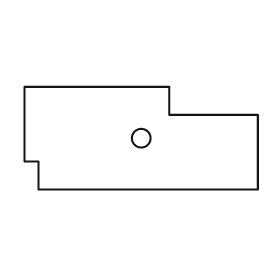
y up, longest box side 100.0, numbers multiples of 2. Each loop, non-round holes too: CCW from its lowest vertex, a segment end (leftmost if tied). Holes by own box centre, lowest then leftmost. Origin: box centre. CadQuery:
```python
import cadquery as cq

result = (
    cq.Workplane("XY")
    .moveTo(-44.0, -22.0)
    .lineTo(50.0, -22.0)
    .lineTo(50.0, 10.0)
    .lineTo(12.0, 10.0)
    .lineTo(12.0, 22.0)
    .lineTo(-50.0, 22.0)
    .lineTo(-50.0, -10.0)
    .lineTo(-44.0, -10.0)
    .close()
    .moveTo(0.0, 0.0)
    .circle(4.0)
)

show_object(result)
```